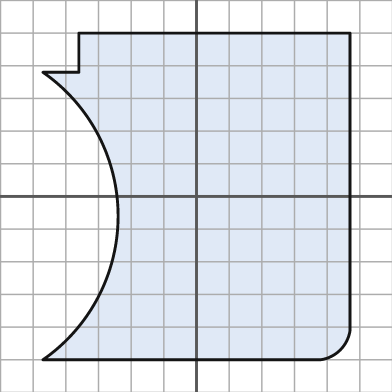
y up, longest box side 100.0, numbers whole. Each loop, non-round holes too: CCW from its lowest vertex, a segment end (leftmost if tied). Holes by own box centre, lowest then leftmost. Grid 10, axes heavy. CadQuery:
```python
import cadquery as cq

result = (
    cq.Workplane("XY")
    .moveTo(-47.0, -50.0)
    .lineTo(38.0, -50.0)
    .threePointArc((44.0, -47.0), (47.0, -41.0))
    .lineTo(47.0, 50.0)
    .lineTo(-36.0, 50.0)
    .lineTo(-36.0, 38.0)
    .lineTo(-47.0, 38.0)
    .threePointArc((-24.0, -6.0), (-47.0, -50.0))
    .close()
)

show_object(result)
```